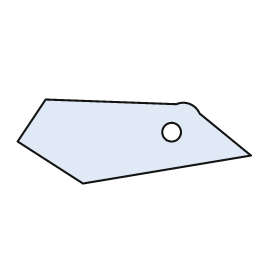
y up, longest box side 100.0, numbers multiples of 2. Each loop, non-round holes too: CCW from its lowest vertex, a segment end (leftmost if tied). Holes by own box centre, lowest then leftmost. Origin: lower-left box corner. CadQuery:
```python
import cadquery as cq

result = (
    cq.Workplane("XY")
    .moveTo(28.0, 0.0)
    .lineTo(100.0, 12.0)
    .lineTo(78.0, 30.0)
    .threePointArc((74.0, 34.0), (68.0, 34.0))
    .lineTo(12.0, 36.0)
    .lineTo(0.0, 18.0)
    .close()
    .moveTo(66.0, 22.0)
    .circle(4.0)
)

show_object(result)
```